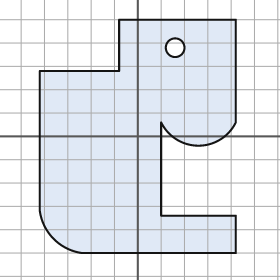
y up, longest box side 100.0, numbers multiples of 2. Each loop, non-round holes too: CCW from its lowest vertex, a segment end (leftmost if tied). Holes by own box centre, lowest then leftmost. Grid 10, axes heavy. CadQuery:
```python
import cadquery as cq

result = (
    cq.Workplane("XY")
    .moveTo(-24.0, -50.0)
    .lineTo(42.0, -50.0)
    .lineTo(42.0, -34.0)
    .lineTo(10.0, -34.0)
    .lineTo(10.0, 6.0)
    .threePointArc((26.0, -4.0), (42.0, 6.0))
    .lineTo(42.0, 50.0)
    .lineTo(-8.0, 50.0)
    .lineTo(-8.0, 28.0)
    .lineTo(-42.0, 28.0)
    .lineTo(-42.0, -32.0)
    .threePointArc((-36.0, -44.0), (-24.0, -50.0))
    .close()
    .moveTo(16.0, 38.0)
    .circle(4.0)
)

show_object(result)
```